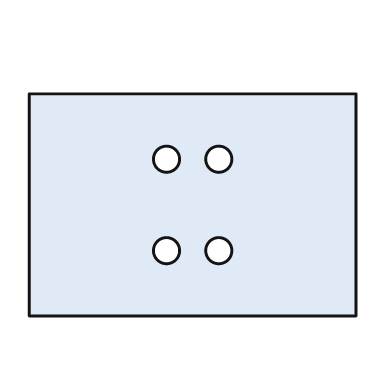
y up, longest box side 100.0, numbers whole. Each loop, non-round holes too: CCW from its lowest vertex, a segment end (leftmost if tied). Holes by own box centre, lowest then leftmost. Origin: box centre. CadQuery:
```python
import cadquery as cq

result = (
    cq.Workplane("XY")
    .moveTo(-50.0, -34.0)
    .lineTo(50.0, -34.0)
    .lineTo(50.0, 34.0)
    .lineTo(-50.0, 34.0)
    .close()
    .moveTo(-8.0, -14.0)
    .circle(4.0)
    .moveTo(8.0, -14.0)
    .circle(4.0)
    .moveTo(-8.0, 14.0)
    .circle(4.0)
    .moveTo(8.0, 14.0)
    .circle(4.0)
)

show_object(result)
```